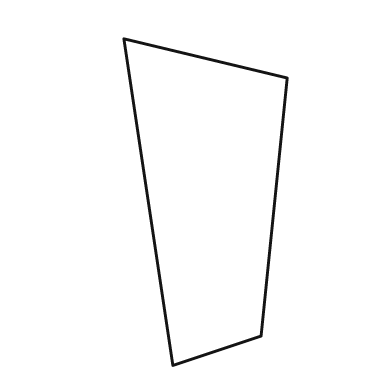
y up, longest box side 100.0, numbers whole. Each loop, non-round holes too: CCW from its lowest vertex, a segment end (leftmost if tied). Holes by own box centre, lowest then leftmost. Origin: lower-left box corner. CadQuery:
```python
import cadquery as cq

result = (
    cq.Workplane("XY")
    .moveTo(15.0, 0.0)
    .lineTo(42.0, 9.0)
    .lineTo(50.0, 88.0)
    .lineTo(0.0, 100.0)
    .close()
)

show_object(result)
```